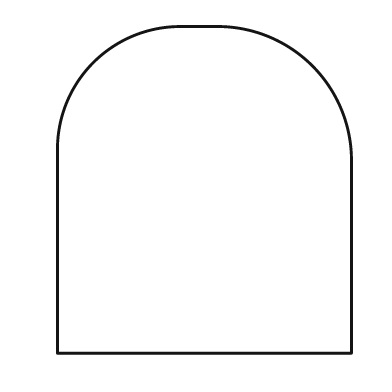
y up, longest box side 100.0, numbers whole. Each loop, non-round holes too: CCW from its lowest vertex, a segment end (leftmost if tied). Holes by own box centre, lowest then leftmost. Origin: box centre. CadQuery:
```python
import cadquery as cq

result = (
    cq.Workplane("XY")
    .moveTo(-45.0, -50.0)
    .lineTo(45.0, -50.0)
    .lineTo(45.0, 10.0)
    .threePointArc((33.0, 38.0), (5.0, 50.0))
    .lineTo(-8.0, 50.0)
    .threePointArc((-34.0, 39.0), (-45.0, 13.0))
    .close()
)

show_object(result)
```